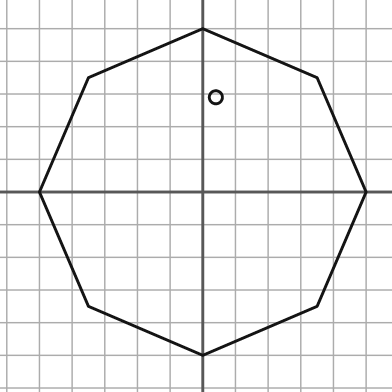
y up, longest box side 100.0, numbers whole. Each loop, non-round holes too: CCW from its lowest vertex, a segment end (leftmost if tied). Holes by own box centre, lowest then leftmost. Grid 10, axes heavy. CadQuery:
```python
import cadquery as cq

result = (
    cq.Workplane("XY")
    .moveTo(0.0, -50.0)
    .lineTo(35.0, -35.0)
    .lineTo(50.0, 0.0)
    .lineTo(35.0, 35.0)
    .lineTo(0.0, 50.0)
    .lineTo(-35.0, 35.0)
    .lineTo(-50.0, 0.0)
    .lineTo(-35.0, -35.0)
    .close()
    .moveTo(4.0, 29.0)
    .circle(2.0)
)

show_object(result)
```